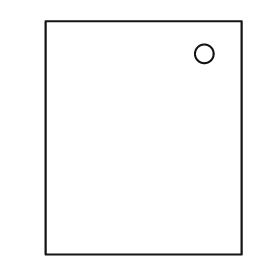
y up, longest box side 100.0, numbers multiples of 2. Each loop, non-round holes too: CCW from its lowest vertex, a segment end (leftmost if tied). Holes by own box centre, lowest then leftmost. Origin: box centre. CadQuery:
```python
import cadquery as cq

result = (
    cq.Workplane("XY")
    .moveTo(-42.0, -50.0)
    .lineTo(42.0, -50.0)
    .lineTo(42.0, 50.0)
    .lineTo(-42.0, 50.0)
    .close()
    .moveTo(26.0, 36.0)
    .circle(4.0)
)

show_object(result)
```